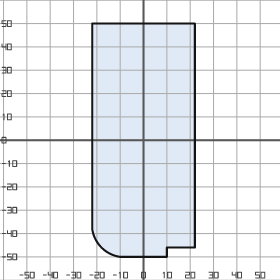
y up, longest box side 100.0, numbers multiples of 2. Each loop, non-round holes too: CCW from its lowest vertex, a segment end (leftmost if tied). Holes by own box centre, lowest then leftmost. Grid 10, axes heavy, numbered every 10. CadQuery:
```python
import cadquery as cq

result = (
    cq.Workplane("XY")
    .moveTo(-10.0, -50.0)
    .lineTo(10.0, -50.0)
    .lineTo(10.0, -46.0)
    .lineTo(22.0, -46.0)
    .lineTo(22.0, 50.0)
    .lineTo(-22.0, 50.0)
    .lineTo(-22.0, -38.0)
    .threePointArc((-18.0, -46.0), (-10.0, -50.0))
    .close()
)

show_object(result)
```